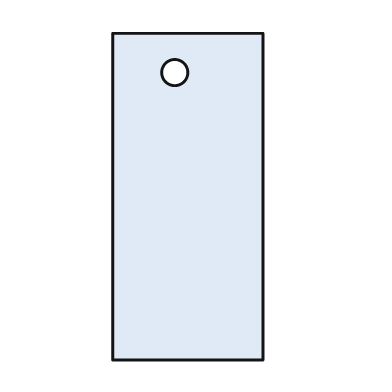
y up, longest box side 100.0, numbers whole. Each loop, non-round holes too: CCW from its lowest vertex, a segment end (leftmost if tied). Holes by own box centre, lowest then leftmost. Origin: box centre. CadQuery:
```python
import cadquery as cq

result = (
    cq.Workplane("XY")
    .moveTo(-23.0, -50.0)
    .lineTo(23.0, -50.0)
    .lineTo(23.0, 50.0)
    .lineTo(-23.0, 50.0)
    .close()
    .moveTo(-4.0, 38.0)
    .circle(4.0)
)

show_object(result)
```